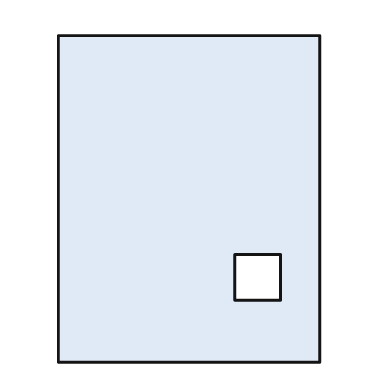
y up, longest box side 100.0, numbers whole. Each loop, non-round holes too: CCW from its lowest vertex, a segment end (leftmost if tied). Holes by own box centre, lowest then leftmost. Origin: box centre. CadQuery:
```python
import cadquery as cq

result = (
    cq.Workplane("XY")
    .moveTo(-40.0, -50.0)
    .lineTo(40.0, -50.0)
    .lineTo(40.0, 50.0)
    .lineTo(-40.0, 50.0)
    .close()
    .moveTo(14.0, -31.0)
    .lineTo(28.0, -31.0)
    .lineTo(28.0, -17.0)
    .lineTo(14.0, -17.0)
    .close()
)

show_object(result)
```